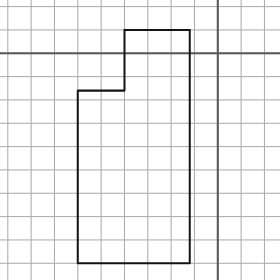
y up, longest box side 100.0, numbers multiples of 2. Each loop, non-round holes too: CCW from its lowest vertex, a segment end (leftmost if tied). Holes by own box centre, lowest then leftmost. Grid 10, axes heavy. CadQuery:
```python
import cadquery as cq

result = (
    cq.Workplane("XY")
    .moveTo(-60.0, -90.0)
    .lineTo(-12.0, -90.0)
    .lineTo(-12.0, 10.0)
    .lineTo(-40.0, 10.0)
    .lineTo(-40.0, -16.0)
    .lineTo(-60.0, -16.0)
    .close()
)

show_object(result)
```